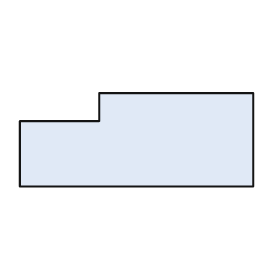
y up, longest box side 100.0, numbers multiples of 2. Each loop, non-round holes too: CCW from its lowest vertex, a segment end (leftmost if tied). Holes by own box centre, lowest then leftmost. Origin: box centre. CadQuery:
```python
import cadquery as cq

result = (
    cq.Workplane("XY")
    .moveTo(-50.0, -20.0)
    .lineTo(50.0, -20.0)
    .lineTo(50.0, 20.0)
    .lineTo(-16.0, 20.0)
    .lineTo(-16.0, 8.0)
    .lineTo(-50.0, 8.0)
    .close()
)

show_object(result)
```